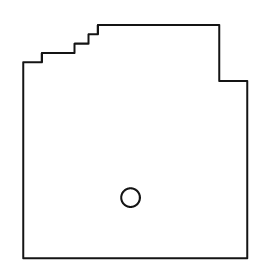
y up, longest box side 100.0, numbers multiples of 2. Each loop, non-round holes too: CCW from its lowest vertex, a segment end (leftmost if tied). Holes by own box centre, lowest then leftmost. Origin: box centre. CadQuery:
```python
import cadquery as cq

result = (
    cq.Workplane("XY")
    .moveTo(-48.0, -50.0)
    .lineTo(48.0, -50.0)
    .lineTo(48.0, 26.0)
    .lineTo(36.0, 26.0)
    .lineTo(36.0, 50.0)
    .lineTo(-16.0, 50.0)
    .lineTo(-16.0, 46.0)
    .lineTo(-20.0, 46.0)
    .lineTo(-20.0, 42.0)
    .lineTo(-26.0, 42.0)
    .lineTo(-26.0, 38.0)
    .lineTo(-40.0, 38.0)
    .lineTo(-40.0, 34.0)
    .lineTo(-48.0, 34.0)
    .close()
    .moveTo(-2.0, -24.0)
    .circle(4.0)
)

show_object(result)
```